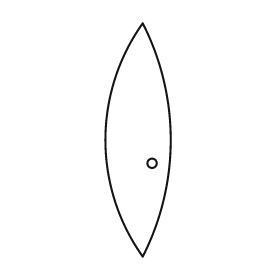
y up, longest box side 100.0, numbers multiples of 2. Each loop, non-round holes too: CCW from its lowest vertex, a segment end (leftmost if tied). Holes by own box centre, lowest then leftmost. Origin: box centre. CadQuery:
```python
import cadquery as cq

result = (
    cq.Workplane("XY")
    .moveTo(2.0, -50.0)
    .threePointArc((14.0, 0.0), (2.0, 50.0))
    .threePointArc((-14.0, 0.0), (2.0, -50.0))
    .close()
    .moveTo(6.0, -10.0)
    .circle(2.0)
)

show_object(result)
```